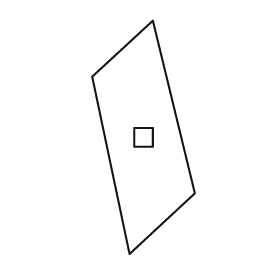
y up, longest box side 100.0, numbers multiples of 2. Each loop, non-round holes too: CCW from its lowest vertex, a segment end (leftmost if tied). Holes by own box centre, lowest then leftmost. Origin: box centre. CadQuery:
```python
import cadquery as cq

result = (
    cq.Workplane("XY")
    .moveTo(-6.0, -50.0)
    .lineTo(22.0, -24.0)
    .lineTo(4.0, 50.0)
    .lineTo(-22.0, 26.0)
    .close()
    .moveTo(-4.0, -4.0)
    .lineTo(4.0, -4.0)
    .lineTo(4.0, 4.0)
    .lineTo(-4.0, 4.0)
    .close()
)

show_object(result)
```